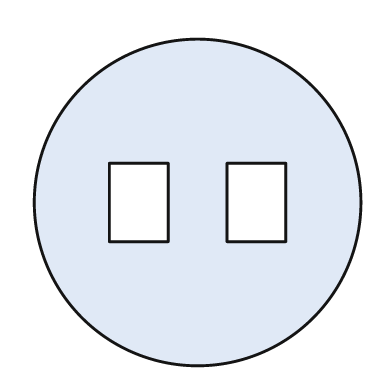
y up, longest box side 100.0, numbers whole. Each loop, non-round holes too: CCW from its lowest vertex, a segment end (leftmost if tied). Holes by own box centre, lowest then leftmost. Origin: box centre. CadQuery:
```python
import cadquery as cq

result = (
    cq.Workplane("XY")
    .moveTo(0.0, 0.0)
    .circle(50.0)
    .moveTo(-27.0, -12.0)
    .lineTo(-9.0, -12.0)
    .lineTo(-9.0, 12.0)
    .lineTo(-27.0, 12.0)
    .close()
    .moveTo(9.0, -12.0)
    .lineTo(27.0, -12.0)
    .lineTo(27.0, 12.0)
    .lineTo(9.0, 12.0)
    .close()
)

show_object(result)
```